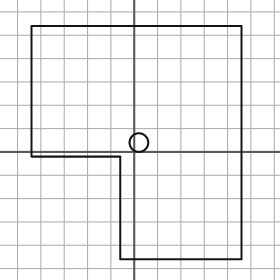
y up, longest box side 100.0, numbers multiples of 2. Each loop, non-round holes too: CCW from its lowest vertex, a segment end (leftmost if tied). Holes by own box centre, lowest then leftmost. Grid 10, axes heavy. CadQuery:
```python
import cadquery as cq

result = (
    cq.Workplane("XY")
    .moveTo(-6.0, -46.0)
    .lineTo(46.0, -46.0)
    .lineTo(46.0, 54.0)
    .lineTo(-44.0, 54.0)
    .lineTo(-44.0, -2.0)
    .lineTo(-6.0, -2.0)
    .close()
    .moveTo(2.0, 4.0)
    .circle(4.0)
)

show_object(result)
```